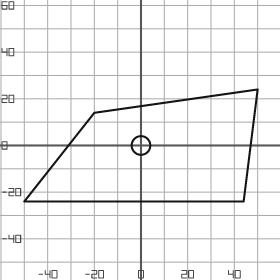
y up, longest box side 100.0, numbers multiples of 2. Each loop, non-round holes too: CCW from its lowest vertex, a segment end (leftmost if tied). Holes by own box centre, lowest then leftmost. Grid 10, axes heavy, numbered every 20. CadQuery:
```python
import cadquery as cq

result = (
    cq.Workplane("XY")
    .moveTo(-50.0, -24.0)
    .lineTo(44.0, -24.0)
    .lineTo(50.0, 24.0)
    .lineTo(-20.0, 14.0)
    .close()
    .moveTo(0.0, 0.0)
    .circle(4.0)
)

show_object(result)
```